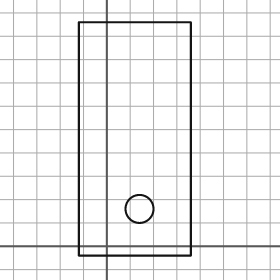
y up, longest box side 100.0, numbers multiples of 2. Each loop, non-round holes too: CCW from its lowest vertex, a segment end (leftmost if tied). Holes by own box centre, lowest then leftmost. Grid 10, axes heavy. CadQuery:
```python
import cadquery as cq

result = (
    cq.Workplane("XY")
    .moveTo(-12.0, -4.0)
    .lineTo(36.0, -4.0)
    .lineTo(36.0, 96.0)
    .lineTo(-12.0, 96.0)
    .close()
    .moveTo(14.0, 16.0)
    .circle(6.0)
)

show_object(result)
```